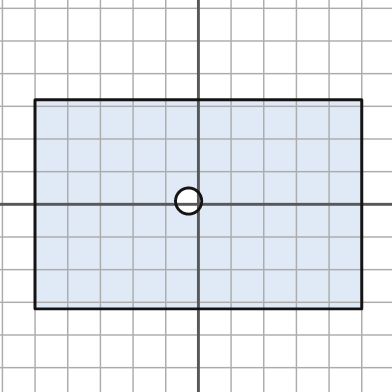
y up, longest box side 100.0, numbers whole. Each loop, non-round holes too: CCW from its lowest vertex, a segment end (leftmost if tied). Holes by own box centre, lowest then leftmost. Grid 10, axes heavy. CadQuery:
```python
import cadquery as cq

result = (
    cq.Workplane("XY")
    .moveTo(-50.0, -32.0)
    .lineTo(50.0, -32.0)
    .lineTo(50.0, 32.0)
    .lineTo(-50.0, 32.0)
    .close()
    .moveTo(-3.0, 1.0)
    .circle(4.0)
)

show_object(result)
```